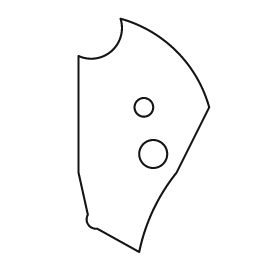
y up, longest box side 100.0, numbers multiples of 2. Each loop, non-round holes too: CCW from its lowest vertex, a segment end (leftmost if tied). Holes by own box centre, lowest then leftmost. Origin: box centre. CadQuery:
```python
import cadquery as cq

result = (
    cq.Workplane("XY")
    .moveTo(-2.0, -50.0)
    .threePointArc((4.0, -32.0), (14.0, -16.0))
    .lineTo(28.0, 12.0)
    .threePointArc((14.0, 36.0), (-10.0, 50.0))
    .threePointArc((-14.0, 36.0), (-28.0, 34.0))
    .lineTo(-28.0, -16.0)
    .lineTo(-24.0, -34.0)
    .threePointArc((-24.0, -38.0), (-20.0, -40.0))
    .close()
    .moveTo(4.0, -8.0)
    .circle(6.0)
    .moveTo(0.0, 12.0)
    .circle(4.0)
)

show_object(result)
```